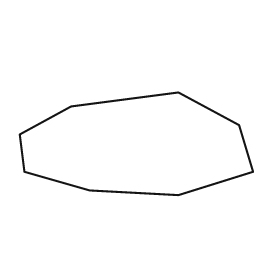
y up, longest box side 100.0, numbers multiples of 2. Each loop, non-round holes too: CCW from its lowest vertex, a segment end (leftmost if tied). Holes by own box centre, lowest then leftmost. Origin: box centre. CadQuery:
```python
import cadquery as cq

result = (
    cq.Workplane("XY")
    .moveTo(18.0, -22.0)
    .lineTo(50.0, -12.0)
    .lineTo(44.0, 8.0)
    .lineTo(18.0, 22.0)
    .lineTo(-28.0, 16.0)
    .lineTo(-50.0, 4.0)
    .lineTo(-48.0, -12.0)
    .lineTo(-20.0, -20.0)
    .close()
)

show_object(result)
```